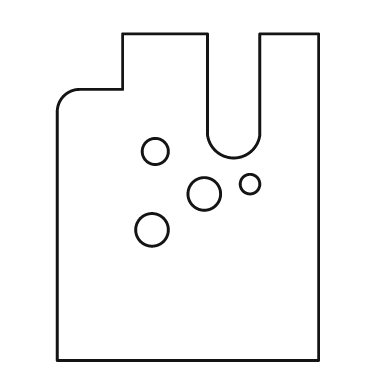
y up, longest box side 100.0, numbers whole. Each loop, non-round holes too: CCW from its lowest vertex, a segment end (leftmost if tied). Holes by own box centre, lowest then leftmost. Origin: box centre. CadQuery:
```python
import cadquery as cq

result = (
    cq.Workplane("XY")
    .moveTo(-40.0, -50.0)
    .lineTo(40.0, -50.0)
    .lineTo(40.0, 50.0)
    .lineTo(22.0, 50.0)
    .lineTo(22.0, 19.0)
    .threePointArc((14.0, 12.0), (6.0, 19.0))
    .lineTo(6.0, 50.0)
    .lineTo(-20.0, 50.0)
    .lineTo(-20.0, 33.0)
    .lineTo(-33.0, 33.0)
    .threePointArc((-38.0, 31.0), (-40.0, 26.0))
    .close()
    .moveTo(-11.0, -10.0)
    .circle(5.0)
    .moveTo(5.0, 1.0)
    .circle(5.0)
    .moveTo(19.0, 4.0)
    .circle(3.0)
    .moveTo(-10.0, 14.0)
    .circle(4.0)
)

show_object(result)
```